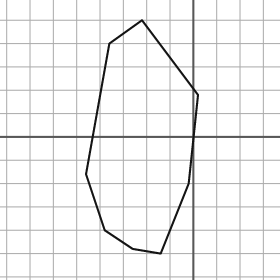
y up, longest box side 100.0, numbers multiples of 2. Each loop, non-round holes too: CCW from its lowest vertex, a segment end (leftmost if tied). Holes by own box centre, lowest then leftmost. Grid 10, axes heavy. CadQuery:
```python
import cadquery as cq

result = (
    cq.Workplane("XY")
    .moveTo(-14.0, -50.0)
    .lineTo(-2.0, -20.0)
    .lineTo(2.0, 18.0)
    .lineTo(-22.0, 50.0)
    .lineTo(-36.0, 40.0)
    .lineTo(-46.0, -16.0)
    .lineTo(-38.0, -40.0)
    .lineTo(-26.0, -48.0)
    .close()
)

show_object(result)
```